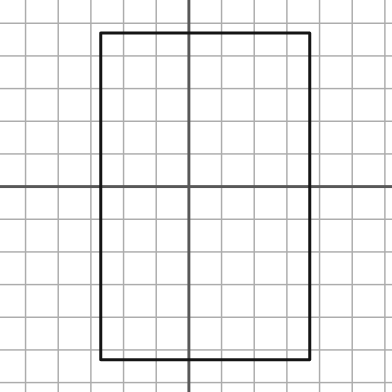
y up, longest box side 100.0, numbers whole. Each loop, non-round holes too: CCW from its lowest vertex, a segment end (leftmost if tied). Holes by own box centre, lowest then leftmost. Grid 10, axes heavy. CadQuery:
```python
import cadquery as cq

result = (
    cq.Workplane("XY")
    .moveTo(-27.0, -53.0)
    .lineTo(37.0, -53.0)
    .lineTo(37.0, 47.0)
    .lineTo(-27.0, 47.0)
    .close()
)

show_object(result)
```